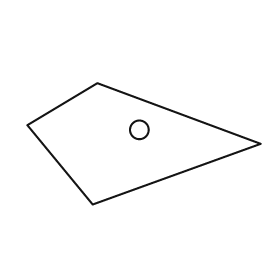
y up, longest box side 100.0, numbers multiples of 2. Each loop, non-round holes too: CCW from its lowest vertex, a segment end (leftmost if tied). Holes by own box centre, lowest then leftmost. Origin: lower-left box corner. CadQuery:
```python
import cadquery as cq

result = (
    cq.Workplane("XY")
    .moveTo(28.0, 0.0)
    .lineTo(100.0, 26.0)
    .lineTo(30.0, 52.0)
    .lineTo(0.0, 34.0)
    .close()
    .moveTo(48.0, 32.0)
    .circle(4.0)
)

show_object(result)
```